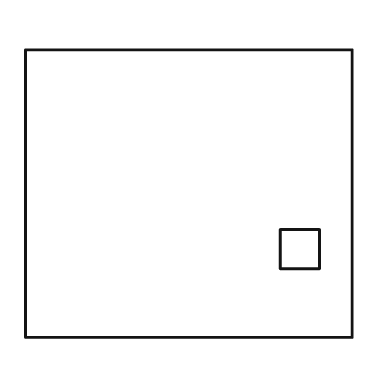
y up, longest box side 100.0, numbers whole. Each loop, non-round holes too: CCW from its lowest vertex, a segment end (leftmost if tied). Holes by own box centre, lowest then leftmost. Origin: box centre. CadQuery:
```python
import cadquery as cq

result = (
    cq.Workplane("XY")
    .moveTo(-50.0, -44.0)
    .lineTo(50.0, -44.0)
    .lineTo(50.0, 44.0)
    .lineTo(-50.0, 44.0)
    .close()
    .moveTo(28.0, -23.0)
    .lineTo(40.0, -23.0)
    .lineTo(40.0, -11.0)
    .lineTo(28.0, -11.0)
    .close()
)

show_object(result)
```